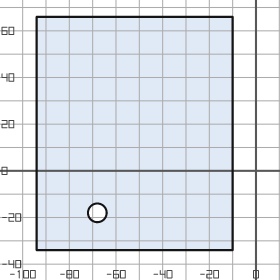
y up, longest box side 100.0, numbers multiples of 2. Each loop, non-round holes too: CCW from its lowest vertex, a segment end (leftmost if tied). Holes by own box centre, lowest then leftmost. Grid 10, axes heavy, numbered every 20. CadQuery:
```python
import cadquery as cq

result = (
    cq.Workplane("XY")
    .moveTo(-94.0, -34.0)
    .lineTo(-10.0, -34.0)
    .lineTo(-10.0, 66.0)
    .lineTo(-94.0, 66.0)
    .close()
    .moveTo(-68.0, -18.0)
    .circle(4.0)
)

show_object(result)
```